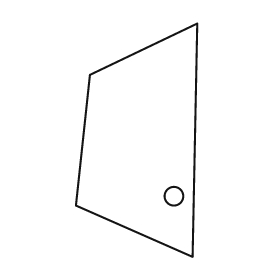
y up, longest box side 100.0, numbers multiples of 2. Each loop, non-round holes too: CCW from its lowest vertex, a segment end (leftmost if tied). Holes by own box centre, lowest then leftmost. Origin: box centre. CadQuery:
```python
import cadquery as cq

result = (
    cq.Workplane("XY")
    .moveTo(24.0, -50.0)
    .lineTo(26.0, 50.0)
    .lineTo(-20.0, 28.0)
    .lineTo(-26.0, -28.0)
    .close()
    .moveTo(16.0, -24.0)
    .circle(4.0)
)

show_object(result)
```